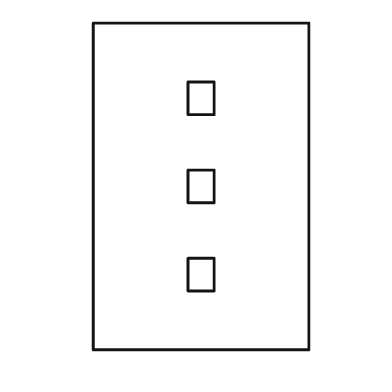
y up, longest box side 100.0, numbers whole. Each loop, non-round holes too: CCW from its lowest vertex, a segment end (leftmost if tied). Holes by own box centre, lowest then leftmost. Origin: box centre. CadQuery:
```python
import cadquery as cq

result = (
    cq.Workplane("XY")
    .moveTo(-33.0, -50.0)
    .lineTo(33.0, -50.0)
    .lineTo(33.0, 50.0)
    .lineTo(-33.0, 50.0)
    .close()
    .moveTo(-4.0, -32.0)
    .lineTo(4.0, -32.0)
    .lineTo(4.0, -22.0)
    .lineTo(-4.0, -22.0)
    .close()
    .moveTo(-4.0, -5.0)
    .lineTo(4.0, -5.0)
    .lineTo(4.0, 5.0)
    .lineTo(-4.0, 5.0)
    .close()
    .moveTo(-4.0, 22.0)
    .lineTo(4.0, 22.0)
    .lineTo(4.0, 32.0)
    .lineTo(-4.0, 32.0)
    .close()
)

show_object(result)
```